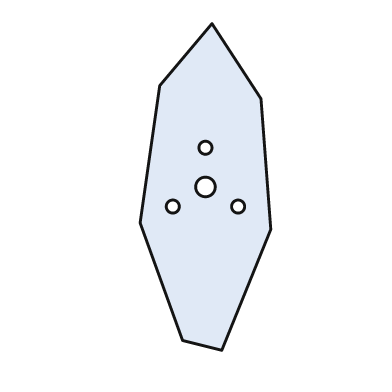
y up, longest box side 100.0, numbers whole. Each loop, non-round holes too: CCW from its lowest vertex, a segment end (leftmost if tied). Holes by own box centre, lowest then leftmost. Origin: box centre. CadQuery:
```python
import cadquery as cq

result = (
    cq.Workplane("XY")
    .moveTo(5.0, -50.0)
    .lineTo(20.0, -13.0)
    .lineTo(17.0, 27.0)
    .lineTo(2.0, 50.0)
    .lineTo(-14.0, 31.0)
    .lineTo(-20.0, -11.0)
    .lineTo(-7.0, -47.0)
    .close()
    .moveTo(-10.0, -6.0)
    .circle(2.0)
    .moveTo(10.0, -6.0)
    .circle(2.0)
    .moveTo(0.0, 0.0)
    .circle(3.0)
    .moveTo(0.0, 12.0)
    .circle(2.0)
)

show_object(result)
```